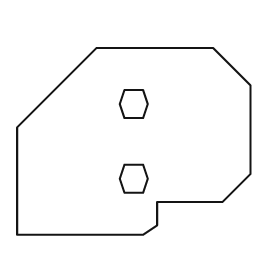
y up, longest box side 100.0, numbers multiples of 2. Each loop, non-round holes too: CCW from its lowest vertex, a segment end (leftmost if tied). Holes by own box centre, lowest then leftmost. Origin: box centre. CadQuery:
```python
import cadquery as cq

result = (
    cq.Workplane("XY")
    .moveTo(-50.0, -40.0)
    .lineTo(4.0, -40.0)
    .lineTo(10.0, -36.0)
    .lineTo(10.0, -26.0)
    .lineTo(38.0, -26.0)
    .lineTo(50.0, -14.0)
    .lineTo(50.0, 24.0)
    .lineTo(34.0, 40.0)
    .lineTo(-16.0, 40.0)
    .lineTo(-50.0, 6.0)
    .close()
    .moveTo(-4.0, -22.0)
    .lineTo(4.0, -22.0)
    .lineTo(6.0, -16.0)
    .lineTo(4.0, -10.0)
    .lineTo(-4.0, -10.0)
    .lineTo(-6.0, -16.0)
    .close()
    .moveTo(-4.0, 10.0)
    .lineTo(4.0, 10.0)
    .lineTo(6.0, 16.0)
    .lineTo(4.0, 22.0)
    .lineTo(-4.0, 22.0)
    .lineTo(-6.0, 16.0)
    .close()
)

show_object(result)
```